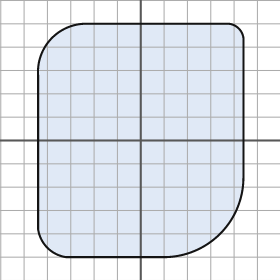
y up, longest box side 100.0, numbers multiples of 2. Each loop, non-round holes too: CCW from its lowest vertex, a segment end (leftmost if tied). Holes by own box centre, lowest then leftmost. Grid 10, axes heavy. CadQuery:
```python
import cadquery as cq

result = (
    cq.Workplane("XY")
    .moveTo(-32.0, -50.0)
    .lineTo(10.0, -50.0)
    .threePointArc((34.0, -40.0), (44.0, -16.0))
    .lineTo(44.0, 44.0)
    .threePointArc((42.0, 48.0), (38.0, 50.0))
    .lineTo(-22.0, 50.0)
    .threePointArc((-38.0, 44.0), (-44.0, 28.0))
    .lineTo(-44.0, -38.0)
    .threePointArc((-40.0, -46.0), (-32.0, -50.0))
    .close()
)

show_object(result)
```